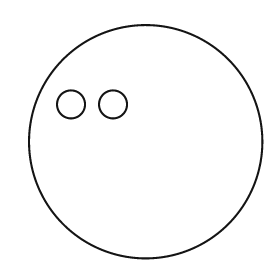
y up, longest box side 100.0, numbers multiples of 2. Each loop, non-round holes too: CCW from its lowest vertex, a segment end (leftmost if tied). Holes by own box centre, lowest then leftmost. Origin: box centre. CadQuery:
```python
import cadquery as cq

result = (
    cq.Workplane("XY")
    .moveTo(0.0, 0.0)
    .circle(50.0)
    .moveTo(-32.0, 16.0)
    .circle(6.0)
    .moveTo(-14.0, 16.0)
    .circle(6.0)
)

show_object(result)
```